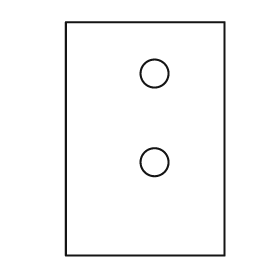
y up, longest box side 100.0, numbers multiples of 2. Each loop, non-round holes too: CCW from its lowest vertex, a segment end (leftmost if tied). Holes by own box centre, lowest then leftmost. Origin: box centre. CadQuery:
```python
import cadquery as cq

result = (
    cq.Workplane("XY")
    .moveTo(-34.0, -50.0)
    .lineTo(34.0, -50.0)
    .lineTo(34.0, 50.0)
    .lineTo(-34.0, 50.0)
    .close()
    .moveTo(4.0, -10.0)
    .circle(6.0)
    .moveTo(4.0, 28.0)
    .circle(6.0)
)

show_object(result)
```